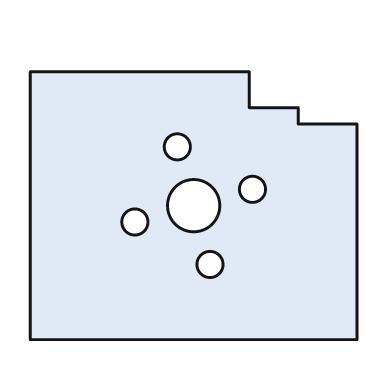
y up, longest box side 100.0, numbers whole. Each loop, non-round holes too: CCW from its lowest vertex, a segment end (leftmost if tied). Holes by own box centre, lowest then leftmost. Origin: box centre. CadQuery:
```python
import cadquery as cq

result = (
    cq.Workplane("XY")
    .moveTo(-50.0, -41.0)
    .lineTo(50.0, -41.0)
    .lineTo(50.0, 25.0)
    .lineTo(32.0, 25.0)
    .lineTo(32.0, 30.0)
    .lineTo(17.0, 30.0)
    .lineTo(17.0, 41.0)
    .lineTo(-50.0, 41.0)
    .close()
    .moveTo(5.0, -18.0)
    .circle(4.0)
    .moveTo(-18.0, -5.0)
    .circle(4.0)
    .moveTo(0.0, 0.0)
    .circle(8.0)
    .moveTo(18.0, 5.0)
    .circle(4.0)
    .moveTo(-5.0, 18.0)
    .circle(4.0)
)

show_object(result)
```